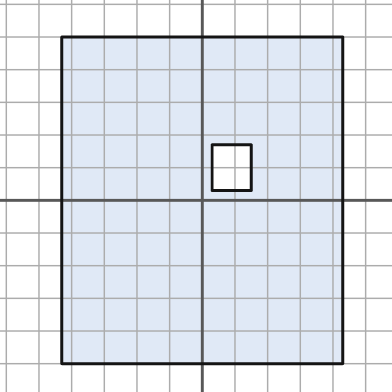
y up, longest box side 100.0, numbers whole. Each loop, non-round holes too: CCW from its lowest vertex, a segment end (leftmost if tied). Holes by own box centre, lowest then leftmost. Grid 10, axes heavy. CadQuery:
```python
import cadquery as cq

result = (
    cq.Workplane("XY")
    .moveTo(-43.0, -50.0)
    .lineTo(43.0, -50.0)
    .lineTo(43.0, 50.0)
    .lineTo(-43.0, 50.0)
    .close()
    .moveTo(3.0, 3.0)
    .lineTo(15.0, 3.0)
    .lineTo(15.0, 17.0)
    .lineTo(3.0, 17.0)
    .close()
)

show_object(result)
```